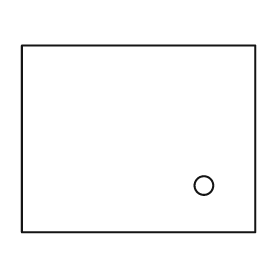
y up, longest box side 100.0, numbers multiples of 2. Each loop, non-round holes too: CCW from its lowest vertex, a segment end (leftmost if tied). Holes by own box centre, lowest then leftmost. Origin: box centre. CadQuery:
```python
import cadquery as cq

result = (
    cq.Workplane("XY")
    .moveTo(-50.0, -40.0)
    .lineTo(50.0, -40.0)
    .lineTo(50.0, 40.0)
    .lineTo(-50.0, 40.0)
    .close()
    .moveTo(28.0, -20.0)
    .circle(4.0)
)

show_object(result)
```